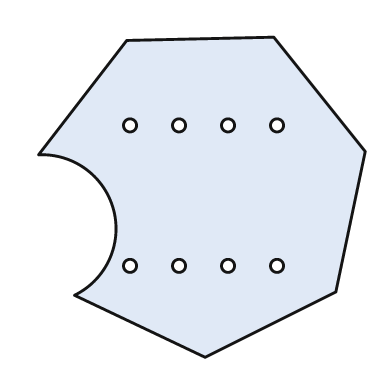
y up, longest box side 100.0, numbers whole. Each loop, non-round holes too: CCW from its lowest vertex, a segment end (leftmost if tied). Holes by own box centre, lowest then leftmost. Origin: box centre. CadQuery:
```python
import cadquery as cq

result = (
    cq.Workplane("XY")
    .moveTo(1.0, -49.0)
    .lineTo(41.0, -29.0)
    .lineTo(50.0, 14.0)
    .lineTo(22.0, 49.0)
    .lineTo(-23.0, 48.0)
    .lineTo(-50.0, 13.0)
    .threePointArc((-27.0, -4.0), (-39.0, -30.0))
    .close()
    .moveTo(-22.0, -21.0)
    .circle(2.0)
    .moveTo(-7.0, -21.0)
    .circle(2.0)
    .moveTo(8.0, -21.0)
    .circle(2.0)
    .moveTo(23.0, -21.0)
    .circle(2.0)
    .moveTo(-22.0, 22.0)
    .circle(2.0)
    .moveTo(-7.0, 22.0)
    .circle(2.0)
    .moveTo(8.0, 22.0)
    .circle(2.0)
    .moveTo(23.0, 22.0)
    .circle(2.0)
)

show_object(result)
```